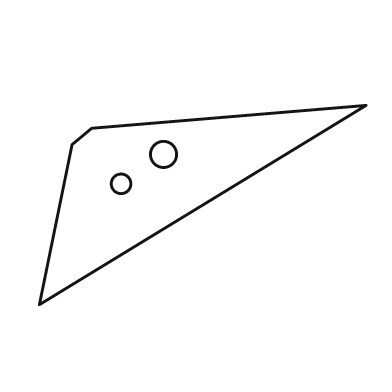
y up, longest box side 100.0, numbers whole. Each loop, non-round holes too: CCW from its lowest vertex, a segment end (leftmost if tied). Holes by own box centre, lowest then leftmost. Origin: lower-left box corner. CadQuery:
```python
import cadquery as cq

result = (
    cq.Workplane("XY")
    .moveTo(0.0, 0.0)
    .lineTo(100.0, 61.0)
    .lineTo(16.0, 54.0)
    .lineTo(10.0, 49.0)
    .close()
    .moveTo(25.0, 37.0)
    .circle(3.0)
    .moveTo(38.0, 46.0)
    .circle(4.0)
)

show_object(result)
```